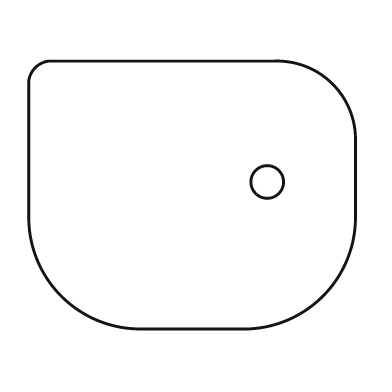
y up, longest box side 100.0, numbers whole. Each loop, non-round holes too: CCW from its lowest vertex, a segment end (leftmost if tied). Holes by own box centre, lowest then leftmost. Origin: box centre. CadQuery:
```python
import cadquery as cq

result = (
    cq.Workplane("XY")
    .moveTo(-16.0, -41.0)
    .lineTo(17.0, -41.0)
    .threePointArc((40.0, -31.0), (50.0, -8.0))
    .lineTo(50.0, 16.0)
    .threePointArc((43.0, 34.0), (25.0, 41.0))
    .lineTo(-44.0, 41.0)
    .threePointArc((-48.0, 39.0), (-50.0, 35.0))
    .lineTo(-50.0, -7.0)
    .threePointArc((-40.0, -31.0), (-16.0, -41.0))
    .close()
    .moveTo(23.0, 4.0)
    .circle(5.0)
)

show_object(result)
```